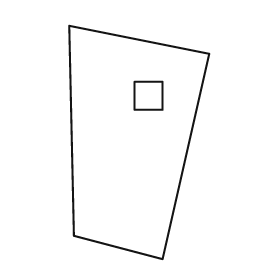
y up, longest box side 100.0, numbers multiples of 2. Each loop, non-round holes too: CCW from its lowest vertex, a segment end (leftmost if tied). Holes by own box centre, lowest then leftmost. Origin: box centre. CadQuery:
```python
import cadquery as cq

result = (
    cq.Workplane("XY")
    .moveTo(10.0, -50.0)
    .lineTo(30.0, 38.0)
    .lineTo(-30.0, 50.0)
    .lineTo(-28.0, -40.0)
    .close()
    .moveTo(-2.0, 14.0)
    .lineTo(10.0, 14.0)
    .lineTo(10.0, 26.0)
    .lineTo(-2.0, 26.0)
    .close()
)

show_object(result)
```